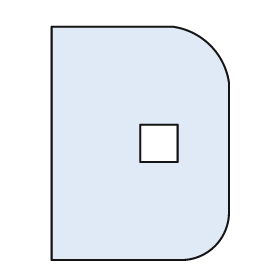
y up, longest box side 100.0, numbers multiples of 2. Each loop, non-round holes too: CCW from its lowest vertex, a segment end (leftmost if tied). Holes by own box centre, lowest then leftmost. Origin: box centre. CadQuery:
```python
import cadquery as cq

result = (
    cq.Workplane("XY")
    .moveTo(-38.0, -50.0)
    .lineTo(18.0, -50.0)
    .threePointArc((32.0, -44.0), (38.0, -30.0))
    .lineTo(38.0, 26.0)
    .threePointArc((30.0, 42.0), (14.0, 50.0))
    .lineTo(-38.0, 50.0)
    .close()
    .moveTo(0.0, -8.0)
    .lineTo(16.0, -8.0)
    .lineTo(16.0, 8.0)
    .lineTo(0.0, 8.0)
    .close()
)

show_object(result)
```